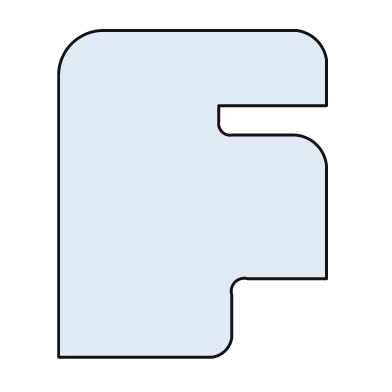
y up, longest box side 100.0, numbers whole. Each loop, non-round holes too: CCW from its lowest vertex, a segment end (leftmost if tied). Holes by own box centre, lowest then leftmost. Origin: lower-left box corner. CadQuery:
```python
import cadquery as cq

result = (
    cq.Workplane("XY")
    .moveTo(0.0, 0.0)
    .lineTo(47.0, 0.0)
    .threePointArc((51.0, 2.0), (53.0, 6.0))
    .lineTo(53.0, 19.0)
    .threePointArc((54.0, 23.0), (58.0, 24.0))
    .lineTo(82.0, 24.0)
    .lineTo(82.0, 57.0)
    .threePointArc((79.0, 65.0), (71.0, 68.0))
    .lineTo(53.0, 68.0)
    .threePointArc((50.0, 69.0), (49.0, 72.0))
    .lineTo(49.0, 77.0)
    .lineTo(82.0, 77.0)
    .lineTo(82.0, 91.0)
    .threePointArc((79.0, 97.0), (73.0, 100.0))
    .lineTo(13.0, 100.0)
    .threePointArc((4.0, 96.0), (0.0, 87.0))
    .close()
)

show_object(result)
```